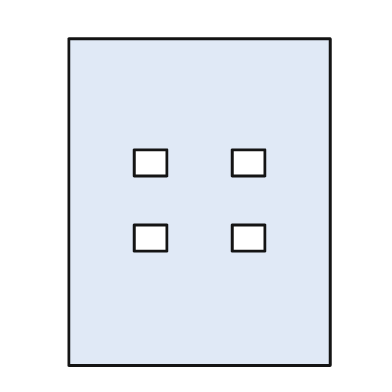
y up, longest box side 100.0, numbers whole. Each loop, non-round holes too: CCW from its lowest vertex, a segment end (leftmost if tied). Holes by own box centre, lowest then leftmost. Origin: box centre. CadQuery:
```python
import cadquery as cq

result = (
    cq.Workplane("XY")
    .moveTo(-40.0, -50.0)
    .lineTo(40.0, -50.0)
    .lineTo(40.0, 50.0)
    .lineTo(-40.0, 50.0)
    .close()
    .moveTo(-20.0, -15.0)
    .lineTo(-10.0, -15.0)
    .lineTo(-10.0, -7.0)
    .lineTo(-20.0, -7.0)
    .close()
    .moveTo(10.0, -15.0)
    .lineTo(20.0, -15.0)
    .lineTo(20.0, -7.0)
    .lineTo(10.0, -7.0)
    .close()
    .moveTo(-20.0, 8.0)
    .lineTo(-10.0, 8.0)
    .lineTo(-10.0, 16.0)
    .lineTo(-20.0, 16.0)
    .close()
    .moveTo(10.0, 8.0)
    .lineTo(20.0, 8.0)
    .lineTo(20.0, 16.0)
    .lineTo(10.0, 16.0)
    .close()
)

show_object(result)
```